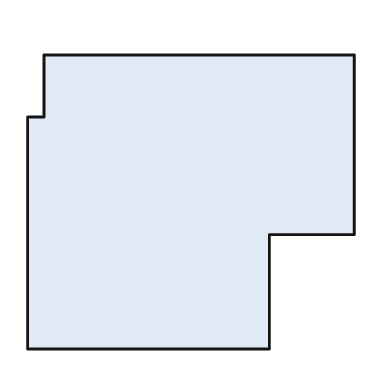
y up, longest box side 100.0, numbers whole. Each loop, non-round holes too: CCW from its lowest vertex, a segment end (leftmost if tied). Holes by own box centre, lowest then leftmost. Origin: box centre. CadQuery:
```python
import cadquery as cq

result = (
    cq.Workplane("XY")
    .moveTo(-50.0, -45.0)
    .lineTo(24.0, -45.0)
    .lineTo(24.0, -10.0)
    .lineTo(50.0, -10.0)
    .lineTo(50.0, 45.0)
    .lineTo(-45.0, 45.0)
    .lineTo(-45.0, 26.0)
    .lineTo(-50.0, 26.0)
    .close()
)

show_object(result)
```